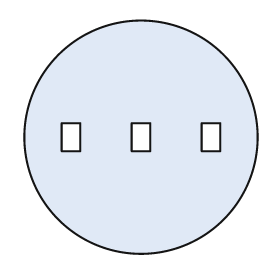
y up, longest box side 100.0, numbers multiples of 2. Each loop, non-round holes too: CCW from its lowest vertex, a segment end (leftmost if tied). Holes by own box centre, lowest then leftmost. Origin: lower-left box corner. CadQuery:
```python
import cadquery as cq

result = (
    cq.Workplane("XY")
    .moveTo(50.0, 50.0)
    .circle(50.0)
    .moveTo(16.0, 44.0)
    .lineTo(24.0, 44.0)
    .lineTo(24.0, 56.0)
    .lineTo(16.0, 56.0)
    .close()
    .moveTo(46.0, 44.0)
    .lineTo(54.0, 44.0)
    .lineTo(54.0, 56.0)
    .lineTo(46.0, 56.0)
    .close()
    .moveTo(76.0, 44.0)
    .lineTo(84.0, 44.0)
    .lineTo(84.0, 56.0)
    .lineTo(76.0, 56.0)
    .close()
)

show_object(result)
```